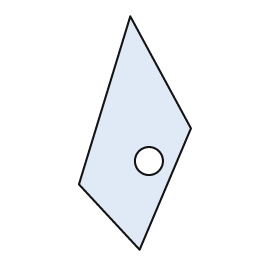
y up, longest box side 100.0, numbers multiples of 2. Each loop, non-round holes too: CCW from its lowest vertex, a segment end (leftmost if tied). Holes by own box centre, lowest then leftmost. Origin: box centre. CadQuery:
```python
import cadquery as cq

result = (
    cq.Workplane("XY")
    .moveTo(2.0, -50.0)
    .lineTo(24.0, 2.0)
    .lineTo(-2.0, 50.0)
    .lineTo(-24.0, -22.0)
    .close()
    .moveTo(6.0, -12.0)
    .circle(6.0)
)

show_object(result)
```